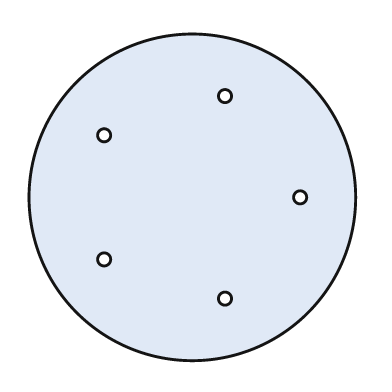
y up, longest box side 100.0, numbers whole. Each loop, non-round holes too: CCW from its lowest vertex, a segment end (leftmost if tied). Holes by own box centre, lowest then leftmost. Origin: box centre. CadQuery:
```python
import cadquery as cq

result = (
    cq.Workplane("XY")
    .moveTo(0.0, 0.0)
    .circle(50.0)
    .moveTo(10.0, -31.0)
    .circle(2.0)
    .moveTo(-27.0, -19.0)
    .circle(2.0)
    .moveTo(33.0, 0.0)
    .circle(2.0)
    .moveTo(-27.0, 19.0)
    .circle(2.0)
    .moveTo(10.0, 31.0)
    .circle(2.0)
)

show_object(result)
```